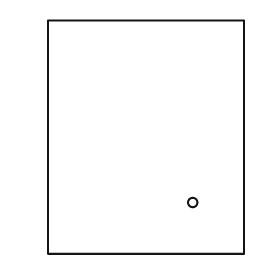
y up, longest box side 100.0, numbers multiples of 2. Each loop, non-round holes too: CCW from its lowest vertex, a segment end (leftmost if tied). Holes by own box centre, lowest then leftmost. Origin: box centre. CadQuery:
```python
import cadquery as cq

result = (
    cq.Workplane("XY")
    .moveTo(-42.0, -50.0)
    .lineTo(42.0, -50.0)
    .lineTo(42.0, 50.0)
    .lineTo(-42.0, 50.0)
    .close()
    .moveTo(20.0, -28.0)
    .circle(2.0)
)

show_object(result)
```